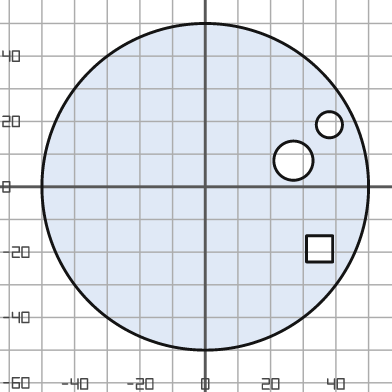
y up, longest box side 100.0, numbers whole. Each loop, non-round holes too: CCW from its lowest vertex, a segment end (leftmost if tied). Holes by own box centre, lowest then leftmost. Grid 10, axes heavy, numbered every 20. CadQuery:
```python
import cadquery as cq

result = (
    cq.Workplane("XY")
    .moveTo(0.0, 0.0)
    .circle(50.0)
    .moveTo(31.0, -23.0)
    .lineTo(39.0, -23.0)
    .lineTo(39.0, -15.0)
    .lineTo(31.0, -15.0)
    .close()
    .moveTo(27.0, 8.0)
    .circle(6.0)
    .moveTo(38.0, 19.0)
    .circle(4.0)
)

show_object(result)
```